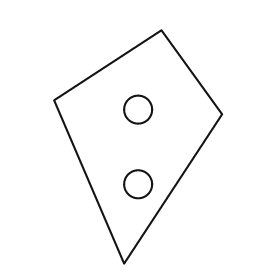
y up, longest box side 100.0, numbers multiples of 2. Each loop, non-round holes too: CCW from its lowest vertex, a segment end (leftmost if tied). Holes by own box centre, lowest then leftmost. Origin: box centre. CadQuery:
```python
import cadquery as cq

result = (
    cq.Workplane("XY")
    .moveTo(-6.0, -50.0)
    .lineTo(36.0, 14.0)
    .lineTo(10.0, 50.0)
    .lineTo(-36.0, 20.0)
    .close()
    .moveTo(0.0, -16.0)
    .circle(6.0)
    .moveTo(0.0, 16.0)
    .circle(6.0)
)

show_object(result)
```